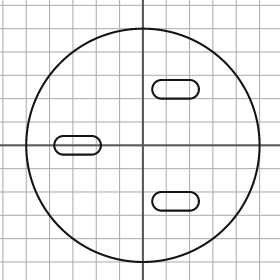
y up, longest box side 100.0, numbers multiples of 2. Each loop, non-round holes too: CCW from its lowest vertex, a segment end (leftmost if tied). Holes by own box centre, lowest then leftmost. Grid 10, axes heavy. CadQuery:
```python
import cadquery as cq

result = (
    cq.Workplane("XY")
    .moveTo(0.0, 0.0)
    .circle(50.0)
    .moveTo(8.0, -28.0)
    .lineTo(20.0, -28.0)
    .threePointArc((24.0, -24.0), (20.0, -20.0))
    .lineTo(8.0, -20.0)
    .threePointArc((4.0, -24.0), (8.0, -28.0))
    .close()
    .moveTo(-34.0, -4.0)
    .lineTo(-22.0, -4.0)
    .threePointArc((-18.0, 0.0), (-22.0, 4.0))
    .lineTo(-34.0, 4.0)
    .threePointArc((-38.0, 0.0), (-34.0, -4.0))
    .close()
    .moveTo(8.0, 20.0)
    .lineTo(20.0, 20.0)
    .threePointArc((24.0, 24.0), (20.0, 28.0))
    .lineTo(8.0, 28.0)
    .threePointArc((4.0, 24.0), (8.0, 20.0))
    .close()
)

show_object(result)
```